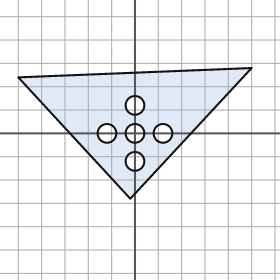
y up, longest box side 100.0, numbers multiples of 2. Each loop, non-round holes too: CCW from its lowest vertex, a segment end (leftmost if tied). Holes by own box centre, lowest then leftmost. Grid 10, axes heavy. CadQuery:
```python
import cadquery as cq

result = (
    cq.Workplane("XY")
    .moveTo(-2.0, -28.0)
    .lineTo(50.0, 28.0)
    .lineTo(-50.0, 24.0)
    .close()
    .moveTo(0.0, -12.0)
    .circle(4.0)
    .moveTo(-12.0, 0.0)
    .circle(4.0)
    .moveTo(0.0, 0.0)
    .circle(4.0)
    .moveTo(12.0, 0.0)
    .circle(4.0)
    .moveTo(0.0, 12.0)
    .circle(4.0)
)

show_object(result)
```